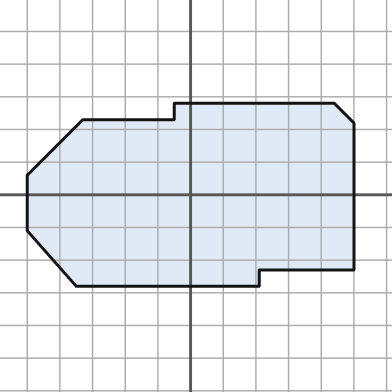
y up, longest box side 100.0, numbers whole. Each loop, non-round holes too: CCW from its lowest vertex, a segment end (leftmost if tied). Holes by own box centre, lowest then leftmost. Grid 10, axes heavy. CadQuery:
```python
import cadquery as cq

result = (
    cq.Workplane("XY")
    .moveTo(-35.0, -28.0)
    .lineTo(21.0, -28.0)
    .lineTo(21.0, -23.0)
    .lineTo(50.0, -23.0)
    .lineTo(50.0, 22.0)
    .lineTo(44.0, 28.0)
    .lineTo(-5.0, 28.0)
    .lineTo(-5.0, 23.0)
    .lineTo(-33.0, 23.0)
    .lineTo(-50.0, 6.0)
    .lineTo(-50.0, -11.0)
    .close()
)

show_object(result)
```